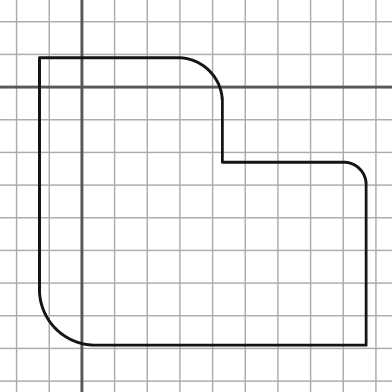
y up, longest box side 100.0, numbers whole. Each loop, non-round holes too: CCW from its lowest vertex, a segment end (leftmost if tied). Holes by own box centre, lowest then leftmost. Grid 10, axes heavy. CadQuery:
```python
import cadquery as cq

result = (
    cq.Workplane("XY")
    .moveTo(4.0, -79.0)
    .lineTo(87.0, -79.0)
    .lineTo(87.0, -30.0)
    .threePointArc((85.0, -25.0), (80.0, -23.0))
    .lineTo(43.0, -23.0)
    .lineTo(43.0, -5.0)
    .threePointArc((39.0, 5.0), (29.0, 9.0))
    .lineTo(-13.0, 9.0)
    .lineTo(-13.0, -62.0)
    .threePointArc((-8.0, -74.0), (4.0, -79.0))
    .close()
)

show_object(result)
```